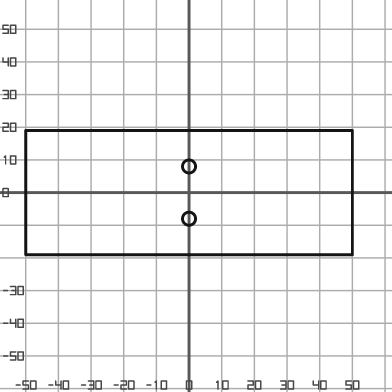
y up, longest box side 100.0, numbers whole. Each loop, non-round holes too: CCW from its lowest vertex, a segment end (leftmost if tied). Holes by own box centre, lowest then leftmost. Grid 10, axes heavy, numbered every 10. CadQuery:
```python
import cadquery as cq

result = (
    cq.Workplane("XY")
    .moveTo(-50.0, -19.0)
    .lineTo(50.0, -19.0)
    .lineTo(50.0, 19.0)
    .lineTo(-50.0, 19.0)
    .close()
    .moveTo(0.0, -8.0)
    .circle(2.0)
    .moveTo(0.0, 8.0)
    .circle(2.0)
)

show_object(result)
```